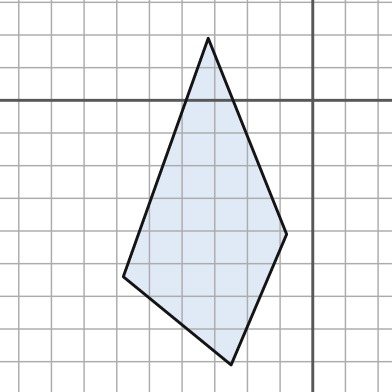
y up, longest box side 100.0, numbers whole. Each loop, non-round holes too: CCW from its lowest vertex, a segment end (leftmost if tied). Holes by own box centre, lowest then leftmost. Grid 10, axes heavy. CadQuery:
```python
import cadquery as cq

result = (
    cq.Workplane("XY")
    .moveTo(-25.0, -81.0)
    .lineTo(-8.0, -41.0)
    .lineTo(-32.0, 19.0)
    .lineTo(-58.0, -54.0)
    .close()
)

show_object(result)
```